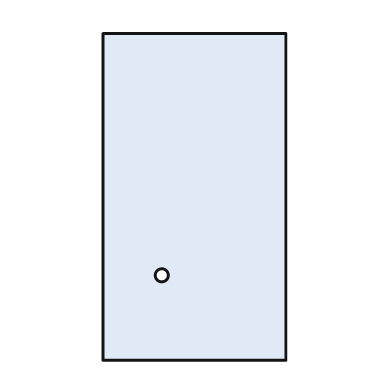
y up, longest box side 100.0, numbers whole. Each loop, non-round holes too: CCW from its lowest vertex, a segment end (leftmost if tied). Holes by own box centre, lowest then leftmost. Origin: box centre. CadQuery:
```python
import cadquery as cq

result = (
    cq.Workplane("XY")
    .moveTo(-28.0, -50.0)
    .lineTo(28.0, -50.0)
    .lineTo(28.0, 50.0)
    .lineTo(-28.0, 50.0)
    .close()
    .moveTo(-10.0, -24.0)
    .circle(2.0)
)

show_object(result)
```